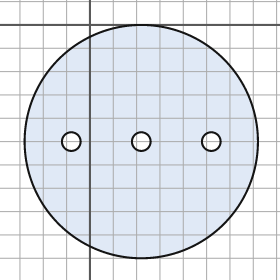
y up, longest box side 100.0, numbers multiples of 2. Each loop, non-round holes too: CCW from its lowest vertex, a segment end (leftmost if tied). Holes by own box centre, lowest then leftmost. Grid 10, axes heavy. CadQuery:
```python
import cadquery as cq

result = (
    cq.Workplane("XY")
    .moveTo(22.0, -50.0)
    .circle(50.0)
    .moveTo(-8.0, -50.0)
    .circle(4.0)
    .moveTo(22.0, -50.0)
    .circle(4.0)
    .moveTo(52.0, -50.0)
    .circle(4.0)
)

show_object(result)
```